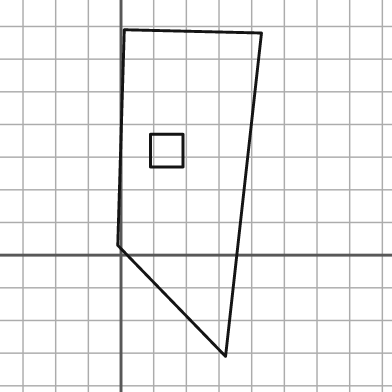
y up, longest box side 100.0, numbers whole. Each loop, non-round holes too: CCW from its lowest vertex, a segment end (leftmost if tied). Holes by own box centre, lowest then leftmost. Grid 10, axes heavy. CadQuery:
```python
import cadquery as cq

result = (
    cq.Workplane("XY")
    .moveTo(32.0, -31.0)
    .lineTo(43.0, 68.0)
    .lineTo(1.0, 69.0)
    .lineTo(-1.0, 3.0)
    .close()
    .moveTo(9.0, 27.0)
    .lineTo(19.0, 27.0)
    .lineTo(19.0, 37.0)
    .lineTo(9.0, 37.0)
    .close()
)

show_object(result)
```